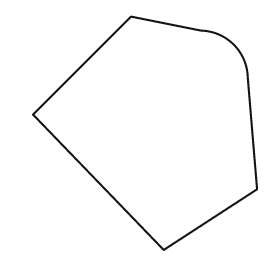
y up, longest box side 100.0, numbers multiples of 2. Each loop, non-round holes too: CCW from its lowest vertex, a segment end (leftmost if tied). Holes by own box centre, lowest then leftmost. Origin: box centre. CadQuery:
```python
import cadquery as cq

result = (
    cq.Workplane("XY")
    .moveTo(8.0, -50.0)
    .lineTo(48.0, -24.0)
    .lineTo(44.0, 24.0)
    .threePointArc((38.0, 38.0), (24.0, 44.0))
    .lineTo(-6.0, 50.0)
    .lineTo(-48.0, 8.0)
    .close()
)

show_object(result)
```